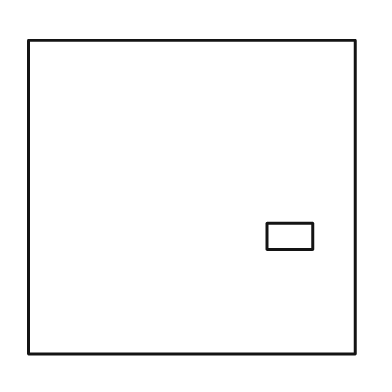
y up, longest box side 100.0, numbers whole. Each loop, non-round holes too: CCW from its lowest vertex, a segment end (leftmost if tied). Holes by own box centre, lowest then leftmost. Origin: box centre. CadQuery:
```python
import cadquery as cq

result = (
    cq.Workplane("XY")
    .moveTo(-50.0, -48.0)
    .lineTo(50.0, -48.0)
    .lineTo(50.0, 48.0)
    .lineTo(-50.0, 48.0)
    .close()
    .moveTo(23.0, -16.0)
    .lineTo(37.0, -16.0)
    .lineTo(37.0, -8.0)
    .lineTo(23.0, -8.0)
    .close()
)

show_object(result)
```